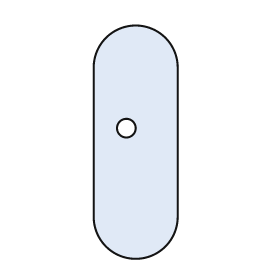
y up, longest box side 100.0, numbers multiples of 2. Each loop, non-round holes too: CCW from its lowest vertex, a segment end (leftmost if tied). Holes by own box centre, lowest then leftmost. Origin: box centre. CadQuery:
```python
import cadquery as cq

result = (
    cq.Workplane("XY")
    .moveTo(-18.0, -32.0)
    .threePointArc((0.0, -50.0), (18.0, -32.0))
    .lineTo(18.0, 32.0)
    .threePointArc((0.0, 50.0), (-18.0, 32.0))
    .close()
    .moveTo(-4.0, 6.0)
    .circle(4.0)
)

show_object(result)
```